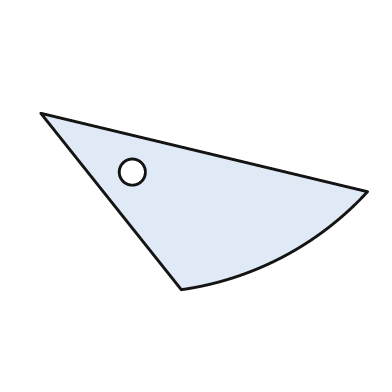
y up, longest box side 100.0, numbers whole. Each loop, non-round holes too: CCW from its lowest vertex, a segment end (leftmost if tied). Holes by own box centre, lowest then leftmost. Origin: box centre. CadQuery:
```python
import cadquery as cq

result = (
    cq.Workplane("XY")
    .moveTo(-7.0, -27.0)
    .threePointArc((24.0, -17.0), (50.0, 3.0))
    .lineTo(-50.0, 27.0)
    .close()
    .moveTo(-22.0, 9.0)
    .circle(4.0)
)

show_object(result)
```